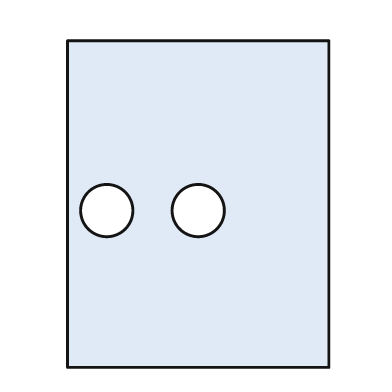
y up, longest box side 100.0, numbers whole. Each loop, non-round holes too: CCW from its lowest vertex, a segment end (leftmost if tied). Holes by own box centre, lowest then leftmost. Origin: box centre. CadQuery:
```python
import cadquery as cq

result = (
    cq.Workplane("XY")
    .moveTo(-40.0, -50.0)
    .lineTo(40.0, -50.0)
    .lineTo(40.0, 50.0)
    .lineTo(-40.0, 50.0)
    .close()
    .moveTo(-28.0, -2.0)
    .circle(8.0)
    .moveTo(0.0, -2.0)
    .circle(8.0)
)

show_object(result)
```